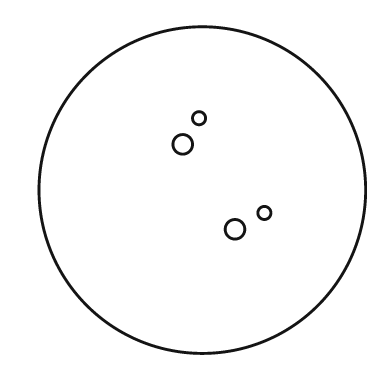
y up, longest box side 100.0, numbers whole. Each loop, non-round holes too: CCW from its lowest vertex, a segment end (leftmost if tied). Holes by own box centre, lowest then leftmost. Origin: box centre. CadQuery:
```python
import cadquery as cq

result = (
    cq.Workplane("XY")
    .moveTo(0.0, 0.0)
    .circle(50.0)
    .moveTo(10.0, -12.0)
    .circle(3.0)
    .moveTo(19.0, -7.0)
    .circle(2.0)
    .moveTo(-6.0, 14.0)
    .circle(3.0)
    .moveTo(-1.0, 22.0)
    .circle(2.0)
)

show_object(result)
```